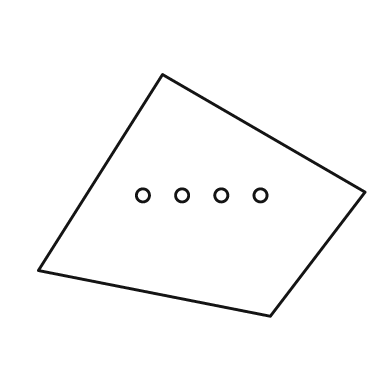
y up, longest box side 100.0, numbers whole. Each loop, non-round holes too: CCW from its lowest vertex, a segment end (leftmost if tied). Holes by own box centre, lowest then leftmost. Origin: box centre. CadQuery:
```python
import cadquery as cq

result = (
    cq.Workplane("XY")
    .moveTo(21.0, -37.0)
    .lineTo(50.0, 1.0)
    .lineTo(-12.0, 37.0)
    .lineTo(-50.0, -23.0)
    .close()
    .moveTo(-18.0, 0.0)
    .circle(2.0)
    .moveTo(-6.0, 0.0)
    .circle(2.0)
    .moveTo(6.0, 0.0)
    .circle(2.0)
    .moveTo(18.0, 0.0)
    .circle(2.0)
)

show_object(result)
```